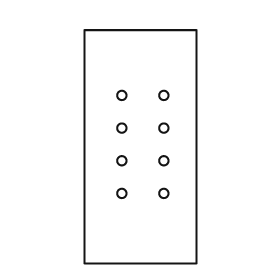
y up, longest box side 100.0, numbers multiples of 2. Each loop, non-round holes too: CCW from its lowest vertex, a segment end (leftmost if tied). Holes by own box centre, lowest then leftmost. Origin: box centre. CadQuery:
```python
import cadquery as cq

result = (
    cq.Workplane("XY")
    .moveTo(-24.0, -50.0)
    .lineTo(24.0, -50.0)
    .lineTo(24.0, 50.0)
    .lineTo(-24.0, 50.0)
    .close()
    .moveTo(-8.0, -20.0)
    .circle(2.0)
    .moveTo(10.0, -20.0)
    .circle(2.0)
    .moveTo(-8.0, -6.0)
    .circle(2.0)
    .moveTo(10.0, -6.0)
    .circle(2.0)
    .moveTo(-8.0, 8.0)
    .circle(2.0)
    .moveTo(10.0, 8.0)
    .circle(2.0)
    .moveTo(-8.0, 22.0)
    .circle(2.0)
    .moveTo(10.0, 22.0)
    .circle(2.0)
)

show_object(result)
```